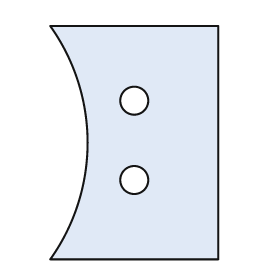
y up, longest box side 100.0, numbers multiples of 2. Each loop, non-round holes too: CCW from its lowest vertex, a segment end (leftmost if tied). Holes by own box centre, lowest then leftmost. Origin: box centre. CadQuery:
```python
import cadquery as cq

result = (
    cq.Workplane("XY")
    .moveTo(-36.0, -50.0)
    .lineTo(36.0, -50.0)
    .lineTo(36.0, 50.0)
    .lineTo(-36.0, 50.0)
    .threePointArc((-20.0, 0.0), (-36.0, -50.0))
    .close()
    .moveTo(0.0, -16.0)
    .circle(6.0)
    .moveTo(0.0, 18.0)
    .circle(6.0)
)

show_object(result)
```